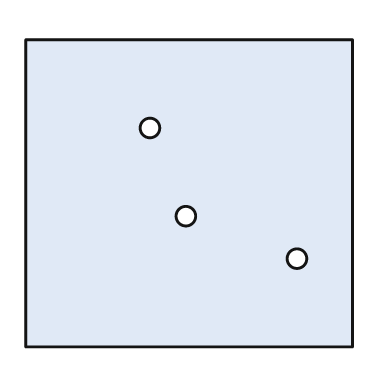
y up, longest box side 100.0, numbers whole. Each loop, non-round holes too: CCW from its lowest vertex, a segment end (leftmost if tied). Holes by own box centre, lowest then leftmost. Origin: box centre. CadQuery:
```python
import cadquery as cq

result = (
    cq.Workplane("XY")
    .moveTo(-50.0, -47.0)
    .lineTo(50.0, -47.0)
    .lineTo(50.0, 47.0)
    .lineTo(-50.0, 47.0)
    .close()
    .moveTo(33.0, -20.0)
    .circle(3.0)
    .moveTo(-1.0, -7.0)
    .circle(3.0)
    .moveTo(-12.0, 20.0)
    .circle(3.0)
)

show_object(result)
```